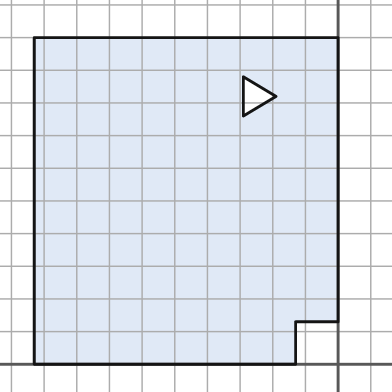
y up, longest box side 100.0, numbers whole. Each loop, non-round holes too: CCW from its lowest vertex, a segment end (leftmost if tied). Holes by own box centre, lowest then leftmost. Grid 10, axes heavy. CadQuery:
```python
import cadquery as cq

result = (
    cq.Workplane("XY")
    .moveTo(-93.0, 0.0)
    .lineTo(-13.0, 0.0)
    .lineTo(-13.0, 13.0)
    .lineTo(0.0, 13.0)
    .lineTo(0.0, 100.0)
    .lineTo(-93.0, 100.0)
    .close()
    .moveTo(-29.0, 76.0)
    .lineTo(-19.0, 82.0)
    .lineTo(-29.0, 88.0)
    .close()
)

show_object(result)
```